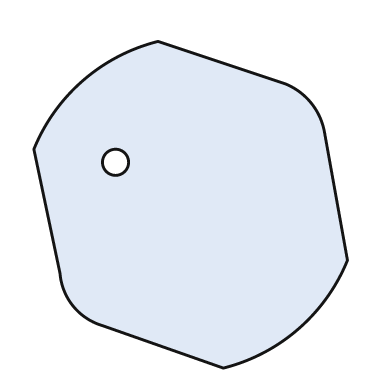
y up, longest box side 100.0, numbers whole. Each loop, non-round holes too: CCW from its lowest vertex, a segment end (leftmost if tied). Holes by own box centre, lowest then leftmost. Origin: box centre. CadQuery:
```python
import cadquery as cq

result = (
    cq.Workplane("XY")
    .moveTo(10.0, -50.0)
    .threePointArc((33.0, -38.0), (48.0, -17.0))
    .lineTo(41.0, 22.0)
    .threePointArc((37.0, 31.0), (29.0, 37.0))
    .lineTo(-10.0, 50.0)
    .threePointArc((-33.0, 38.0), (-48.0, 17.0))
    .lineTo(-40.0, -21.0)
    .threePointArc((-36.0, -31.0), (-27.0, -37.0))
    .close()
    .moveTo(-23.0, 13.0)
    .circle(4.0)
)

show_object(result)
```